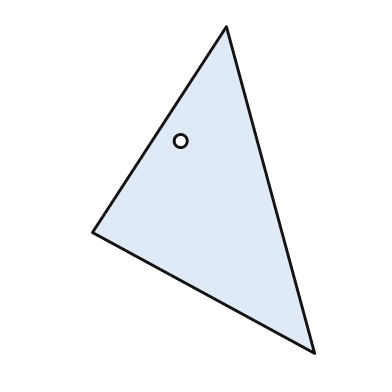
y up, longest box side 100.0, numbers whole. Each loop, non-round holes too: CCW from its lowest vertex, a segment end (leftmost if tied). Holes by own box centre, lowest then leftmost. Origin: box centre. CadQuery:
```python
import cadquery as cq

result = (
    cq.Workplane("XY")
    .moveTo(34.0, -50.0)
    .lineTo(7.0, 50.0)
    .lineTo(-34.0, -13.0)
    .close()
    .moveTo(-7.0, 15.0)
    .circle(2.0)
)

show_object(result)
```